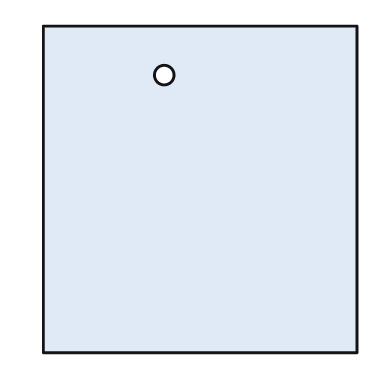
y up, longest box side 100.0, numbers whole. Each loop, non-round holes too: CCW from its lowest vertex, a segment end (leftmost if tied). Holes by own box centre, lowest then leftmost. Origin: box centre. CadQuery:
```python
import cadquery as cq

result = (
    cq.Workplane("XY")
    .moveTo(-48.0, -50.0)
    .lineTo(48.0, -50.0)
    .lineTo(48.0, 50.0)
    .lineTo(-48.0, 50.0)
    .close()
    .moveTo(-11.0, 35.0)
    .circle(3.0)
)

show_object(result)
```